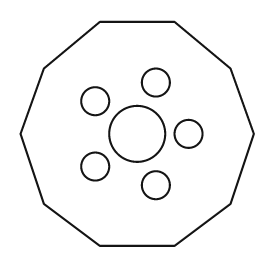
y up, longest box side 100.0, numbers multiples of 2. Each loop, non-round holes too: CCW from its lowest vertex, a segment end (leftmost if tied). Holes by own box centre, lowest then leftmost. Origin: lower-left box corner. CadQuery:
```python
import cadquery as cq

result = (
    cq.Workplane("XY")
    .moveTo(34.0, 0.0)
    .lineTo(66.0, 0.0)
    .lineTo(90.0, 18.0)
    .lineTo(100.0, 48.0)
    .lineTo(90.0, 76.0)
    .lineTo(66.0, 96.0)
    .lineTo(34.0, 96.0)
    .lineTo(10.0, 76.0)
    .lineTo(0.0, 48.0)
    .lineTo(10.0, 18.0)
    .close()
    .moveTo(58.0, 26.0)
    .circle(6.0)
    .moveTo(32.0, 34.0)
    .circle(6.0)
    .moveTo(50.0, 48.0)
    .circle(12.0)
    .moveTo(72.0, 48.0)
    .circle(6.0)
    .moveTo(32.0, 62.0)
    .circle(6.0)
    .moveTo(58.0, 70.0)
    .circle(6.0)
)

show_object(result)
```